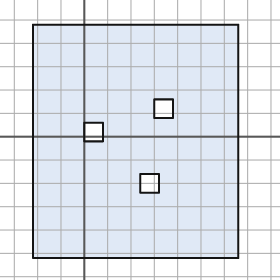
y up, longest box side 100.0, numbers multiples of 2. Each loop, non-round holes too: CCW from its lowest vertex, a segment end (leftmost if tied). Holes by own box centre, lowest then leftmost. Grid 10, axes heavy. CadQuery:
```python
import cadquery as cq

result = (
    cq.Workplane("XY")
    .moveTo(-22.0, -52.0)
    .lineTo(66.0, -52.0)
    .lineTo(66.0, 48.0)
    .lineTo(-22.0, 48.0)
    .close()
    .moveTo(24.0, -24.0)
    .lineTo(32.0, -24.0)
    .lineTo(32.0, -16.0)
    .lineTo(24.0, -16.0)
    .close()
    .moveTo(0.0, -2.0)
    .lineTo(8.0, -2.0)
    .lineTo(8.0, 6.0)
    .lineTo(0.0, 6.0)
    .close()
    .moveTo(30.0, 8.0)
    .lineTo(38.0, 8.0)
    .lineTo(38.0, 16.0)
    .lineTo(30.0, 16.0)
    .close()
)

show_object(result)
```